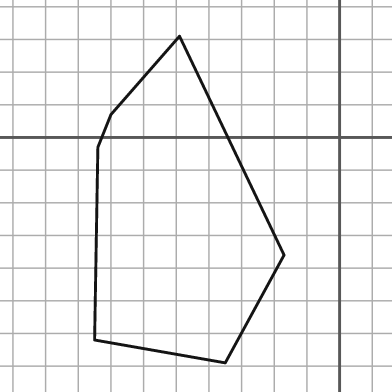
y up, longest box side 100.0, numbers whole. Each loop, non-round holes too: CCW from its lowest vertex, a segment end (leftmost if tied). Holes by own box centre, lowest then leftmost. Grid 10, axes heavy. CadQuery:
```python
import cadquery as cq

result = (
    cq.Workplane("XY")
    .moveTo(-35.0, -69.0)
    .lineTo(-17.0, -36.0)
    .lineTo(-49.0, 31.0)
    .lineTo(-70.0, 7.0)
    .lineTo(-74.0, -3.0)
    .lineTo(-75.0, -62.0)
    .close()
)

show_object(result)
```